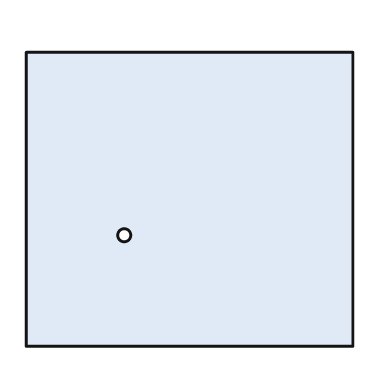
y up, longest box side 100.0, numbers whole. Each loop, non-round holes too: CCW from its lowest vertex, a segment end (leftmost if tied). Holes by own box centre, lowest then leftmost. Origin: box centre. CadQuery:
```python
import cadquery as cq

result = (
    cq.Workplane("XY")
    .moveTo(-50.0, -45.0)
    .lineTo(50.0, -45.0)
    .lineTo(50.0, 45.0)
    .lineTo(-50.0, 45.0)
    .close()
    .moveTo(-20.0, -11.0)
    .circle(2.0)
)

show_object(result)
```